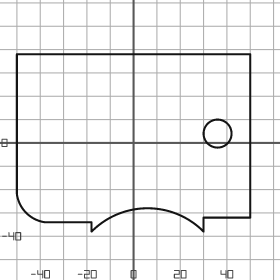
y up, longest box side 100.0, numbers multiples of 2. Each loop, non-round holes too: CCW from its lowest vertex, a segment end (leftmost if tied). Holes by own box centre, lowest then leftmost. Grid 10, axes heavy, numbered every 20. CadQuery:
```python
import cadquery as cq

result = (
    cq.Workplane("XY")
    .moveTo(-18.0, -38.0)
    .threePointArc((6.0, -28.0), (30.0, -38.0))
    .lineTo(30.0, -32.0)
    .lineTo(50.0, -32.0)
    .lineTo(50.0, 38.0)
    .lineTo(-50.0, 38.0)
    .lineTo(-50.0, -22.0)
    .threePointArc((-46.0, -30.0), (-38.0, -34.0))
    .lineTo(-18.0, -34.0)
    .close()
    .moveTo(36.0, 4.0)
    .circle(6.0)
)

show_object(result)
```